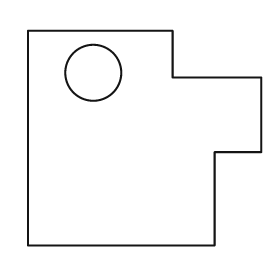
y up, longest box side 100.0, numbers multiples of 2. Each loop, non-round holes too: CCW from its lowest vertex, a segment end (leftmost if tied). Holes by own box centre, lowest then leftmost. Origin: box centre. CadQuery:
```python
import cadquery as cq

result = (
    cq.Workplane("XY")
    .moveTo(-50.0, -46.0)
    .lineTo(30.0, -46.0)
    .lineTo(30.0, -6.0)
    .lineTo(50.0, -6.0)
    .lineTo(50.0, 26.0)
    .lineTo(12.0, 26.0)
    .lineTo(12.0, 46.0)
    .lineTo(-50.0, 46.0)
    .close()
    .moveTo(-22.0, 28.0)
    .circle(12.0)
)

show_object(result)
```